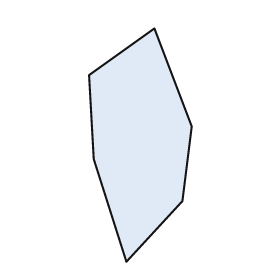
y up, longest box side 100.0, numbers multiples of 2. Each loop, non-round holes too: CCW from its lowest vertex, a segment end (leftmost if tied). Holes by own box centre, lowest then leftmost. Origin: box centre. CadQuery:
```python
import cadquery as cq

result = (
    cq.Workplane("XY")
    .moveTo(-6.0, -50.0)
    .lineTo(18.0, -24.0)
    .lineTo(22.0, 8.0)
    .lineTo(6.0, 50.0)
    .lineTo(-22.0, 30.0)
    .lineTo(-20.0, -6.0)
    .close()
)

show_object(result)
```